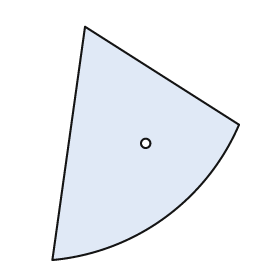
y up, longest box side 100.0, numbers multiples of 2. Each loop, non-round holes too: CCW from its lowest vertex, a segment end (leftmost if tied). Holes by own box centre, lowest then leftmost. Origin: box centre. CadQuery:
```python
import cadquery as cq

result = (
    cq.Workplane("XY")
    .moveTo(-40.0, -50.0)
    .threePointArc((8.0, -32.0), (40.0, 8.0))
    .lineTo(-26.0, 50.0)
    .close()
    .moveTo(0.0, 0.0)
    .circle(2.0)
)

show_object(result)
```